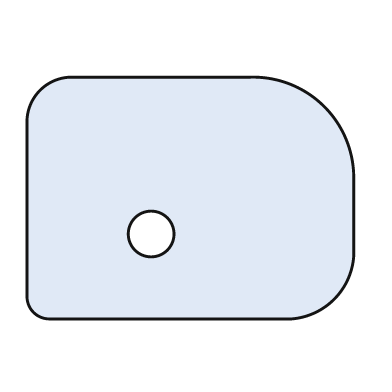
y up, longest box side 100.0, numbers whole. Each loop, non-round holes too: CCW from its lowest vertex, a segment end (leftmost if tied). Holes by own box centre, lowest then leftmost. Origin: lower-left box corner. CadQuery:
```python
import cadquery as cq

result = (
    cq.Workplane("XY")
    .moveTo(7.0, 0.0)
    .lineTo(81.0, 0.0)
    .threePointArc((94.0, 6.0), (100.0, 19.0))
    .lineTo(100.0, 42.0)
    .threePointArc((91.0, 65.0), (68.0, 74.0))
    .lineTo(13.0, 74.0)
    .threePointArc((4.0, 70.0), (0.0, 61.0))
    .lineTo(0.0, 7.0)
    .threePointArc((2.0, 2.0), (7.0, 0.0))
    .close()
    .moveTo(38.0, 26.0)
    .circle(7.0)
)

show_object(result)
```